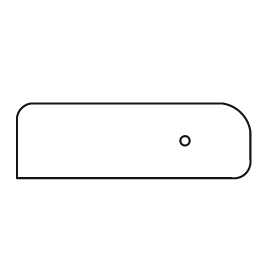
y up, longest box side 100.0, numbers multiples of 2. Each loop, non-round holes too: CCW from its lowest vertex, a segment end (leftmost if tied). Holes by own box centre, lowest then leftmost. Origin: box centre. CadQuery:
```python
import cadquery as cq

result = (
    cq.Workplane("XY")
    .moveTo(-50.0, -16.0)
    .lineTo(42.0, -16.0)
    .threePointArc((48.0, -14.0), (50.0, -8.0))
    .lineTo(50.0, 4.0)
    .threePointArc((46.0, 12.0), (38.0, 16.0))
    .lineTo(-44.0, 16.0)
    .threePointArc((-48.0, 14.0), (-50.0, 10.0))
    .close()
    .moveTo(22.0, 0.0)
    .circle(2.0)
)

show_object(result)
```